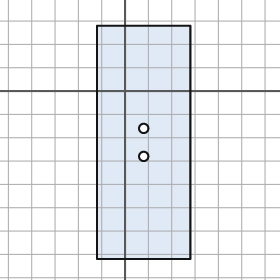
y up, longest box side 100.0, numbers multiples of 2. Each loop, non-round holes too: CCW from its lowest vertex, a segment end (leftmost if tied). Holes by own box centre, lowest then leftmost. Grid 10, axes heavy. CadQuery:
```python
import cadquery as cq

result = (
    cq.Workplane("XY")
    .moveTo(-12.0, -72.0)
    .lineTo(28.0, -72.0)
    .lineTo(28.0, 28.0)
    .lineTo(-12.0, 28.0)
    .close()
    .moveTo(8.0, -28.0)
    .circle(2.0)
    .moveTo(8.0, -16.0)
    .circle(2.0)
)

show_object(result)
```